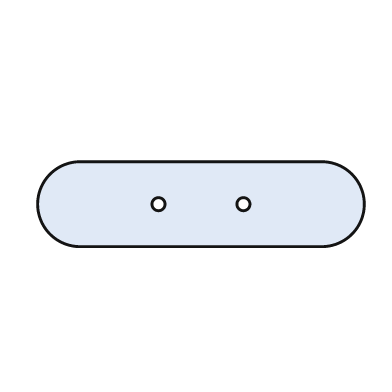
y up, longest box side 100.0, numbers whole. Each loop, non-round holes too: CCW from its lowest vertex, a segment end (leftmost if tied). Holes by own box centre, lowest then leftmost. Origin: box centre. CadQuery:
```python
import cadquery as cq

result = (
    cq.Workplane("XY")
    .moveTo(-37.0, -13.0)
    .lineTo(37.0, -13.0)
    .threePointArc((50.0, 0.0), (37.0, 13.0))
    .lineTo(-37.0, 13.0)
    .threePointArc((-50.0, 0.0), (-37.0, -13.0))
    .close()
    .moveTo(-13.0, 0.0)
    .circle(2.0)
    .moveTo(13.0, 0.0)
    .circle(2.0)
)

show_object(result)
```